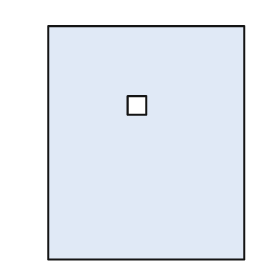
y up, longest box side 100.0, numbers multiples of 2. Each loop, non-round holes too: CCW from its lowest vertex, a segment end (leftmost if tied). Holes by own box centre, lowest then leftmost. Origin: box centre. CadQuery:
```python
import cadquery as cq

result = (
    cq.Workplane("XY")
    .moveTo(-42.0, -50.0)
    .lineTo(42.0, -50.0)
    .lineTo(42.0, 50.0)
    .lineTo(-42.0, 50.0)
    .close()
    .moveTo(-8.0, 12.0)
    .lineTo(0.0, 12.0)
    .lineTo(0.0, 20.0)
    .lineTo(-8.0, 20.0)
    .close()
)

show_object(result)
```